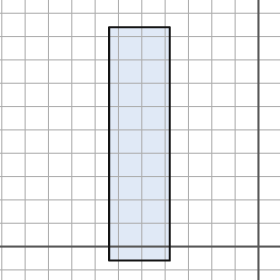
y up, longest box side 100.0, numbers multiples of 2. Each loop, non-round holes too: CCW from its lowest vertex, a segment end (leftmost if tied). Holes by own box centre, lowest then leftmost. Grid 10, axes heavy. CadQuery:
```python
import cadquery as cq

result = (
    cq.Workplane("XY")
    .moveTo(-64.0, -6.0)
    .lineTo(-38.0, -6.0)
    .lineTo(-38.0, 94.0)
    .lineTo(-64.0, 94.0)
    .close()
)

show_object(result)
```